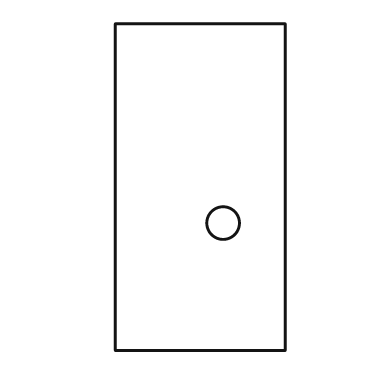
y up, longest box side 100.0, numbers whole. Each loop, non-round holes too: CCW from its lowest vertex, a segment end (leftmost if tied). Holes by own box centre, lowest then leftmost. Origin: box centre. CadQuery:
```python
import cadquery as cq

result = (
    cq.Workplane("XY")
    .moveTo(-26.0, -50.0)
    .lineTo(26.0, -50.0)
    .lineTo(26.0, 50.0)
    .lineTo(-26.0, 50.0)
    .close()
    .moveTo(7.0, -11.0)
    .circle(5.0)
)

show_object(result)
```